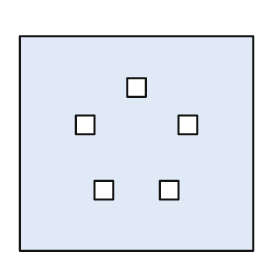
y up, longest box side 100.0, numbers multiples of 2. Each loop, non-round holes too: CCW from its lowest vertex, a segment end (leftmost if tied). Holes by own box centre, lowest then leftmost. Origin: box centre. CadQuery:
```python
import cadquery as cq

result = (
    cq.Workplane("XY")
    .moveTo(-50.0, -46.0)
    .lineTo(50.0, -46.0)
    .lineTo(50.0, 46.0)
    .lineTo(-50.0, 46.0)
    .close()
    .moveTo(-18.0, -24.0)
    .lineTo(-10.0, -24.0)
    .lineTo(-10.0, -16.0)
    .lineTo(-18.0, -16.0)
    .close()
    .moveTo(10.0, -24.0)
    .lineTo(18.0, -24.0)
    .lineTo(18.0, -16.0)
    .lineTo(10.0, -16.0)
    .close()
    .moveTo(-26.0, 4.0)
    .lineTo(-18.0, 4.0)
    .lineTo(-18.0, 12.0)
    .lineTo(-26.0, 12.0)
    .close()
    .moveTo(18.0, 4.0)
    .lineTo(26.0, 4.0)
    .lineTo(26.0, 12.0)
    .lineTo(18.0, 12.0)
    .close()
    .moveTo(-4.0, 20.0)
    .lineTo(4.0, 20.0)
    .lineTo(4.0, 28.0)
    .lineTo(-4.0, 28.0)
    .close()
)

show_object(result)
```